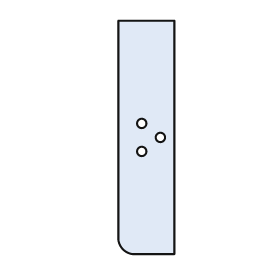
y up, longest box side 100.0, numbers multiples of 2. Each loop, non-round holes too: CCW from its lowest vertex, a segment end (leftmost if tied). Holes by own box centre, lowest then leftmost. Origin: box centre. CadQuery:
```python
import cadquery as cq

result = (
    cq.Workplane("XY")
    .moveTo(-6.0, -50.0)
    .lineTo(12.0, -50.0)
    .lineTo(12.0, 50.0)
    .lineTo(-12.0, 50.0)
    .lineTo(-12.0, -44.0)
    .threePointArc((-10.0, -48.0), (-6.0, -50.0))
    .close()
    .moveTo(-2.0, -6.0)
    .circle(2.0)
    .moveTo(6.0, 0.0)
    .circle(2.0)
    .moveTo(-2.0, 6.0)
    .circle(2.0)
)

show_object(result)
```